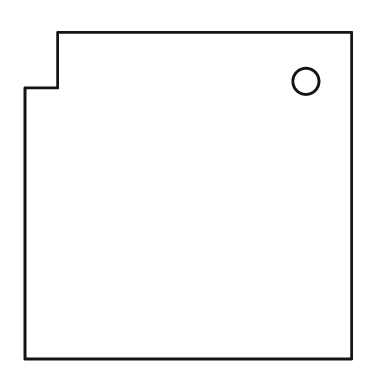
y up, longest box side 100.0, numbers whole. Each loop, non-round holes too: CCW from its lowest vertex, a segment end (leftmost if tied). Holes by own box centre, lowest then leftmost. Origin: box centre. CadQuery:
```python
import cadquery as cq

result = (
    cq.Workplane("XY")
    .moveTo(-50.0, -50.0)
    .lineTo(50.0, -50.0)
    .lineTo(50.0, 50.0)
    .lineTo(-40.0, 50.0)
    .lineTo(-40.0, 33.0)
    .lineTo(-50.0, 33.0)
    .close()
    .moveTo(36.0, 35.0)
    .circle(4.0)
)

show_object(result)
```